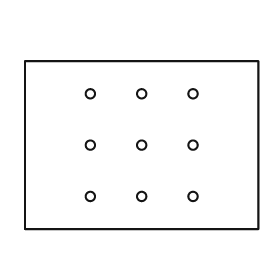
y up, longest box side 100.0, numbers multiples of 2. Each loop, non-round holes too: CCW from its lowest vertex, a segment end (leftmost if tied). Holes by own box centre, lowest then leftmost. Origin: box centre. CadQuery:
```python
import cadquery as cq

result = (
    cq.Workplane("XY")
    .moveTo(-50.0, -36.0)
    .lineTo(50.0, -36.0)
    .lineTo(50.0, 36.0)
    .lineTo(-50.0, 36.0)
    .close()
    .moveTo(-22.0, -22.0)
    .circle(2.0)
    .moveTo(0.0, -22.0)
    .circle(2.0)
    .moveTo(22.0, -22.0)
    .circle(2.0)
    .moveTo(-22.0, 0.0)
    .circle(2.0)
    .moveTo(0.0, 0.0)
    .circle(2.0)
    .moveTo(22.0, 0.0)
    .circle(2.0)
    .moveTo(-22.0, 22.0)
    .circle(2.0)
    .moveTo(0.0, 22.0)
    .circle(2.0)
    .moveTo(22.0, 22.0)
    .circle(2.0)
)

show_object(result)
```